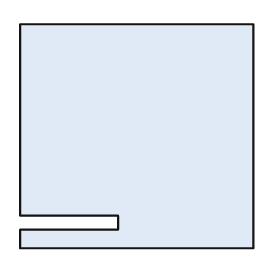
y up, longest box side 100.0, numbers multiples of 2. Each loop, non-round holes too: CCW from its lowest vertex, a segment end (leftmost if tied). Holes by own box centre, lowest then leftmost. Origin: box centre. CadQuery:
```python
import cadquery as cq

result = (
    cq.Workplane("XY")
    .moveTo(-50.0, -48.0)
    .lineTo(50.0, -48.0)
    .lineTo(50.0, 48.0)
    .lineTo(-50.0, 48.0)
    .lineTo(-50.0, -34.0)
    .lineTo(-8.0, -34.0)
    .lineTo(-8.0, -40.0)
    .lineTo(-50.0, -40.0)
    .close()
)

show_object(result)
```